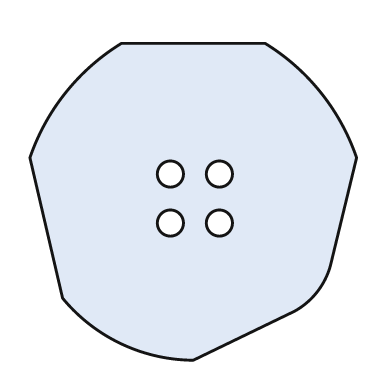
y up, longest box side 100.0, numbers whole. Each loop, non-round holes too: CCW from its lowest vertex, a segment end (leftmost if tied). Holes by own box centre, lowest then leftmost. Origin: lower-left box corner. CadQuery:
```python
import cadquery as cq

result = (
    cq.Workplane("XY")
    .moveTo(50.0, 0.0)
    .lineTo(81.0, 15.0)
    .threePointArc((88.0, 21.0), (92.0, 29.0))
    .lineTo(100.0, 62.0)
    .threePointArc((89.0, 82.0), (72.0, 97.0))
    .lineTo(28.0, 97.0)
    .threePointArc((11.0, 82.0), (0.0, 62.0))
    .lineTo(10.0, 19.0)
    .threePointArc((28.0, 5.0), (50.0, 0.0))
    .close()
    .moveTo(43.0, 42.0)
    .circle(4.0)
    .moveTo(58.0, 42.0)
    .circle(4.0)
    .moveTo(43.0, 57.0)
    .circle(4.0)
    .moveTo(58.0, 57.0)
    .circle(4.0)
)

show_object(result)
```